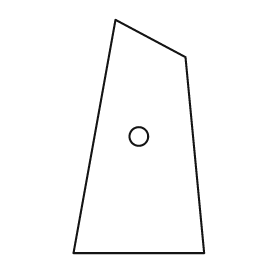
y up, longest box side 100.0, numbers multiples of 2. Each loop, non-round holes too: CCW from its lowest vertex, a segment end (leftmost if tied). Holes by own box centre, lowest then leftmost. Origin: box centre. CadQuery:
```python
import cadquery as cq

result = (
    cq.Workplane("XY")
    .moveTo(-28.0, -50.0)
    .lineTo(28.0, -50.0)
    .lineTo(20.0, 34.0)
    .lineTo(-10.0, 50.0)
    .close()
    .moveTo(0.0, 0.0)
    .circle(4.0)
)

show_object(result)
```